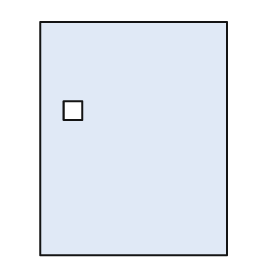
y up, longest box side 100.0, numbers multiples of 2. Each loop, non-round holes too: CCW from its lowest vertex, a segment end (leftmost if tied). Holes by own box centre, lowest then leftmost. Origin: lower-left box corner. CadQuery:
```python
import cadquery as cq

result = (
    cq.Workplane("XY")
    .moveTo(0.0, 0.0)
    .lineTo(80.0, 0.0)
    .lineTo(80.0, 100.0)
    .lineTo(0.0, 100.0)
    .close()
    .moveTo(10.0, 58.0)
    .lineTo(18.0, 58.0)
    .lineTo(18.0, 66.0)
    .lineTo(10.0, 66.0)
    .close()
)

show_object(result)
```